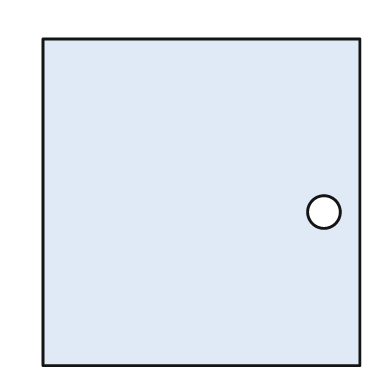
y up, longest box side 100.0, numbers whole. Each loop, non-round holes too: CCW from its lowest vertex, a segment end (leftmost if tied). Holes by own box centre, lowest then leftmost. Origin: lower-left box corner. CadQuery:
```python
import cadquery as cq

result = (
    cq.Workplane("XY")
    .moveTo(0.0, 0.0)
    .lineTo(97.0, 0.0)
    .lineTo(97.0, 100.0)
    .lineTo(0.0, 100.0)
    .close()
    .moveTo(86.0, 47.0)
    .circle(5.0)
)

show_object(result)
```